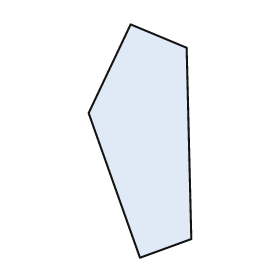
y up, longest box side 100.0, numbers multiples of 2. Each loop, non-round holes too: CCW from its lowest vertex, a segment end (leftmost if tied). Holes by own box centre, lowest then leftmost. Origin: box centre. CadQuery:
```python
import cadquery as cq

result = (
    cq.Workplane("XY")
    .moveTo(0.0, -50.0)
    .lineTo(22.0, -42.0)
    .lineTo(20.0, 40.0)
    .lineTo(-4.0, 50.0)
    .lineTo(-22.0, 12.0)
    .close()
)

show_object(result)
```